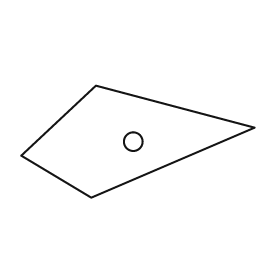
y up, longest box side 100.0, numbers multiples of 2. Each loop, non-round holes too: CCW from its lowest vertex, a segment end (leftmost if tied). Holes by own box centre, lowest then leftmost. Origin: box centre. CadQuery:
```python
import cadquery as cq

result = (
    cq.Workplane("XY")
    .moveTo(-20.0, -24.0)
    .lineTo(50.0, 6.0)
    .lineTo(-18.0, 24.0)
    .lineTo(-50.0, -6.0)
    .close()
    .moveTo(-2.0, 0.0)
    .circle(4.0)
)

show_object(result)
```